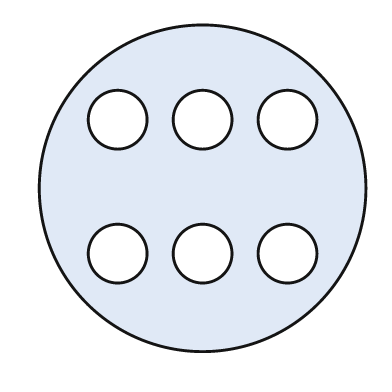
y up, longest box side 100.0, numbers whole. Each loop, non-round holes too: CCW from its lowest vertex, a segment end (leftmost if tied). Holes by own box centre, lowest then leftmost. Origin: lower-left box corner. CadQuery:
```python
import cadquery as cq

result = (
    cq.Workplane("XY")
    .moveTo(50.0, 50.0)
    .circle(50.0)
    .moveTo(24.0, 30.0)
    .circle(9.0)
    .moveTo(50.0, 30.0)
    .circle(9.0)
    .moveTo(76.0, 30.0)
    .circle(9.0)
    .moveTo(24.0, 71.0)
    .circle(9.0)
    .moveTo(50.0, 71.0)
    .circle(9.0)
    .moveTo(76.0, 71.0)
    .circle(9.0)
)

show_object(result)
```